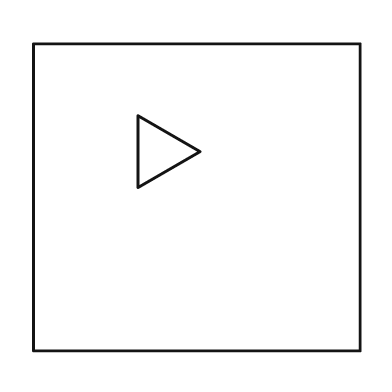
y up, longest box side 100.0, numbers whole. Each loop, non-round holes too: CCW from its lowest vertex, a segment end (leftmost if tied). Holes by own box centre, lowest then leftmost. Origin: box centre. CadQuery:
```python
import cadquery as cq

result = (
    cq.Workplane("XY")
    .moveTo(-50.0, -47.0)
    .lineTo(50.0, -47.0)
    .lineTo(50.0, 47.0)
    .lineTo(-50.0, 47.0)
    .close()
    .moveTo(-18.0, 3.0)
    .lineTo(1.0, 14.0)
    .lineTo(-18.0, 25.0)
    .close()
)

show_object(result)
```